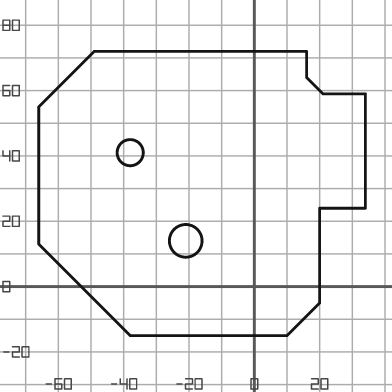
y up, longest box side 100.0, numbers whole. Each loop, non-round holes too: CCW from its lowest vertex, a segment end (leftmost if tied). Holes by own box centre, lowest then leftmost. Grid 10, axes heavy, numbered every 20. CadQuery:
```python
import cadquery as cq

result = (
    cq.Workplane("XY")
    .moveTo(-38.0, -15.0)
    .lineTo(10.0, -15.0)
    .lineTo(20.0, -5.0)
    .lineTo(20.0, 24.0)
    .lineTo(34.0, 24.0)
    .lineTo(34.0, 59.0)
    .lineTo(21.0, 59.0)
    .lineTo(16.0, 64.0)
    .lineTo(16.0, 72.0)
    .lineTo(-49.0, 72.0)
    .lineTo(-66.0, 55.0)
    .lineTo(-66.0, 13.0)
    .close()
    .moveTo(-21.0, 14.0)
    .circle(5.0)
    .moveTo(-38.0, 41.0)
    .circle(4.0)
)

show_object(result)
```